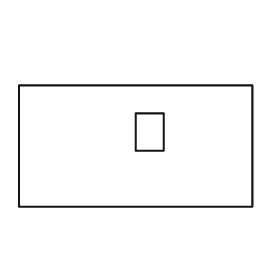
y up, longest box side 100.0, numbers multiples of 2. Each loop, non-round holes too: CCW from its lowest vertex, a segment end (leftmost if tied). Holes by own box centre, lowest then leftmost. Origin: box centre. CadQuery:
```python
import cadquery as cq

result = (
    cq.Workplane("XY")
    .moveTo(-50.0, -26.0)
    .lineTo(50.0, -26.0)
    .lineTo(50.0, 26.0)
    .lineTo(-50.0, 26.0)
    .close()
    .moveTo(0.0, -2.0)
    .lineTo(12.0, -2.0)
    .lineTo(12.0, 14.0)
    .lineTo(0.0, 14.0)
    .close()
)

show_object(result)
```